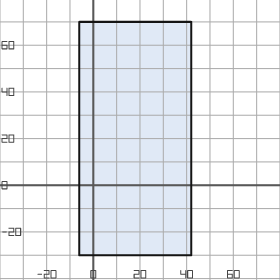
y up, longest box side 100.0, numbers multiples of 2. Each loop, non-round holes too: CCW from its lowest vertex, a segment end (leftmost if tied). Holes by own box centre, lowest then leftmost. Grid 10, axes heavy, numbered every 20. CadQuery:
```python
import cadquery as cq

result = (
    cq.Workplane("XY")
    .moveTo(-6.0, -30.0)
    .lineTo(42.0, -30.0)
    .lineTo(42.0, 70.0)
    .lineTo(-6.0, 70.0)
    .close()
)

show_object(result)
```